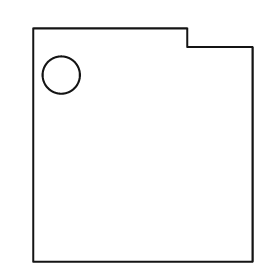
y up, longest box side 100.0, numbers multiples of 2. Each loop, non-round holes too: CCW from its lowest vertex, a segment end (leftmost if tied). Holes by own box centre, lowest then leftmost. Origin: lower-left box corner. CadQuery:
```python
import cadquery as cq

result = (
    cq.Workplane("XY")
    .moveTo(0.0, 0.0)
    .lineTo(94.0, 0.0)
    .lineTo(94.0, 92.0)
    .lineTo(66.0, 92.0)
    .lineTo(66.0, 100.0)
    .lineTo(0.0, 100.0)
    .close()
    .moveTo(12.0, 80.0)
    .circle(8.0)
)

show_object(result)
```